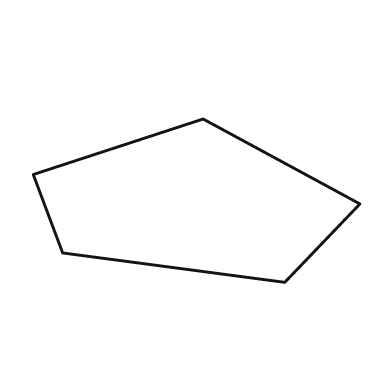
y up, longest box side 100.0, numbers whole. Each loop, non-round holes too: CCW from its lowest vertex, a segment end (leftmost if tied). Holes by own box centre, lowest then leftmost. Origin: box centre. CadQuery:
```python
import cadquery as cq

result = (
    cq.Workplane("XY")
    .moveTo(27.0, -25.0)
    .lineTo(50.0, -1.0)
    .lineTo(2.0, 25.0)
    .lineTo(-50.0, 8.0)
    .lineTo(-41.0, -16.0)
    .close()
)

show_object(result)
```